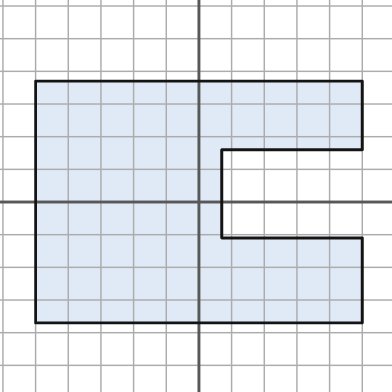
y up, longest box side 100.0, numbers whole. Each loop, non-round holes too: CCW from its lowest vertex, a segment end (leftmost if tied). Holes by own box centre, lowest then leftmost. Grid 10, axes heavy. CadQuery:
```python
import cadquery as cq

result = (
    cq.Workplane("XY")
    .moveTo(-50.0, -37.0)
    .lineTo(50.0, -37.0)
    .lineTo(50.0, -11.0)
    .lineTo(7.0, -11.0)
    .lineTo(7.0, 16.0)
    .lineTo(50.0, 16.0)
    .lineTo(50.0, 37.0)
    .lineTo(-50.0, 37.0)
    .close()
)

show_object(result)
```